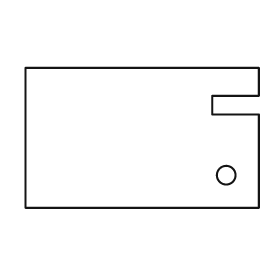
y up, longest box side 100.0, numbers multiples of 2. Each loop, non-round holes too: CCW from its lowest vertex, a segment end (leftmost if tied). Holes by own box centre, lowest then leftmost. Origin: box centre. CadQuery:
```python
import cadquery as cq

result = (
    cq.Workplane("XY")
    .moveTo(-50.0, -30.0)
    .lineTo(50.0, -30.0)
    .lineTo(50.0, 10.0)
    .lineTo(30.0, 10.0)
    .lineTo(30.0, 18.0)
    .lineTo(50.0, 18.0)
    .lineTo(50.0, 30.0)
    .lineTo(-50.0, 30.0)
    .close()
    .moveTo(36.0, -16.0)
    .circle(4.0)
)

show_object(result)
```